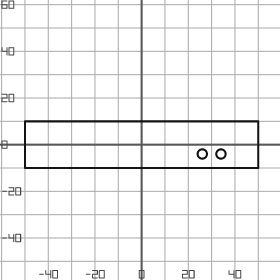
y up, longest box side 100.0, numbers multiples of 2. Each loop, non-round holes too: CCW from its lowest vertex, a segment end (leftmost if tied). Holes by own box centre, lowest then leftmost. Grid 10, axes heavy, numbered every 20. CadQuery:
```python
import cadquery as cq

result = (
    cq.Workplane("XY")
    .moveTo(-50.0, -10.0)
    .lineTo(50.0, -10.0)
    .lineTo(50.0, 10.0)
    .lineTo(-50.0, 10.0)
    .close()
    .moveTo(26.0, -4.0)
    .circle(2.0)
    .moveTo(34.0, -4.0)
    .circle(2.0)
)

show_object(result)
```